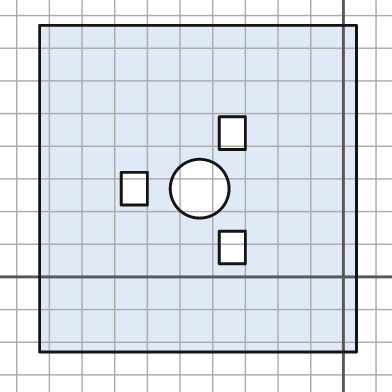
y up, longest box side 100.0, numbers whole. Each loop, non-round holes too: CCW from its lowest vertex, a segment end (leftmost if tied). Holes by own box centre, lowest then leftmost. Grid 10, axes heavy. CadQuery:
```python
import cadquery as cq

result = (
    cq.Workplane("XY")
    .moveTo(-93.0, -23.0)
    .lineTo(4.0, -23.0)
    .lineTo(4.0, 77.0)
    .lineTo(-93.0, 77.0)
    .close()
    .moveTo(-38.0, 4.0)
    .lineTo(-30.0, 4.0)
    .lineTo(-30.0, 14.0)
    .lineTo(-38.0, 14.0)
    .close()
    .moveTo(-68.0, 22.0)
    .lineTo(-60.0, 22.0)
    .lineTo(-60.0, 32.0)
    .lineTo(-68.0, 32.0)
    .close()
    .moveTo(-44.0, 27.0)
    .circle(9.0)
    .moveTo(-38.0, 39.0)
    .lineTo(-30.0, 39.0)
    .lineTo(-30.0, 49.0)
    .lineTo(-38.0, 49.0)
    .close()
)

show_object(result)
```